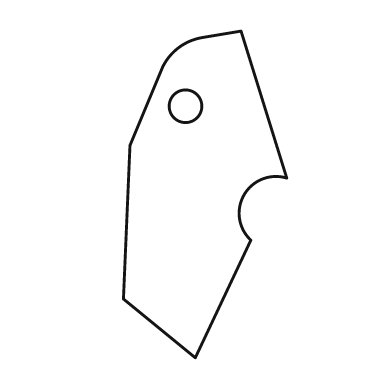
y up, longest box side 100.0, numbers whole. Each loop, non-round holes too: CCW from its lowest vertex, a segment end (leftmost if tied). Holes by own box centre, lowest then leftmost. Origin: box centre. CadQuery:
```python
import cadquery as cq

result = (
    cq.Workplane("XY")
    .moveTo(-3.0, -50.0)
    .lineTo(14.0, -14.0)
    .threePointArc((12.0, 0.0), (25.0, 5.0))
    .lineTo(11.0, 50.0)
    .lineTo(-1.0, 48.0)
    .threePointArc((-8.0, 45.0), (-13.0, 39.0))
    .lineTo(-23.0, 15.0)
    .lineTo(-25.0, -32.0)
    .close()
    .moveTo(-6.0, 27.0)
    .circle(5.0)
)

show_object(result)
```